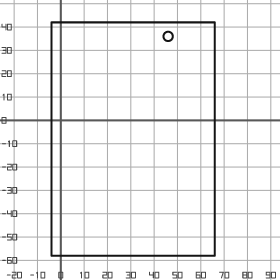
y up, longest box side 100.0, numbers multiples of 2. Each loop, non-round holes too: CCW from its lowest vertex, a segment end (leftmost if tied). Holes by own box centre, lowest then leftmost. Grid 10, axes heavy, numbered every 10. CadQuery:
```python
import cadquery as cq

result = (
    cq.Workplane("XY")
    .moveTo(-4.0, -58.0)
    .lineTo(66.0, -58.0)
    .lineTo(66.0, 42.0)
    .lineTo(-4.0, 42.0)
    .close()
    .moveTo(46.0, 36.0)
    .circle(2.0)
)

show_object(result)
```